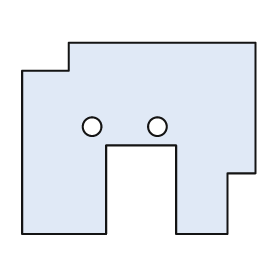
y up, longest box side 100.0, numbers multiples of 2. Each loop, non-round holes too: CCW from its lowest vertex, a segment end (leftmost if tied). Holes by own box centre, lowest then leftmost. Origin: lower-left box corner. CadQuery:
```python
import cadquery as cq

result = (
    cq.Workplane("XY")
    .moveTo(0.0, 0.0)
    .lineTo(36.0, 0.0)
    .lineTo(36.0, 38.0)
    .lineTo(66.0, 38.0)
    .lineTo(66.0, 0.0)
    .lineTo(88.0, 0.0)
    .lineTo(88.0, 26.0)
    .lineTo(100.0, 26.0)
    .lineTo(100.0, 82.0)
    .lineTo(20.0, 82.0)
    .lineTo(20.0, 70.0)
    .lineTo(0.0, 70.0)
    .close()
    .moveTo(30.0, 46.0)
    .circle(4.0)
    .moveTo(58.0, 46.0)
    .circle(4.0)
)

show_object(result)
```